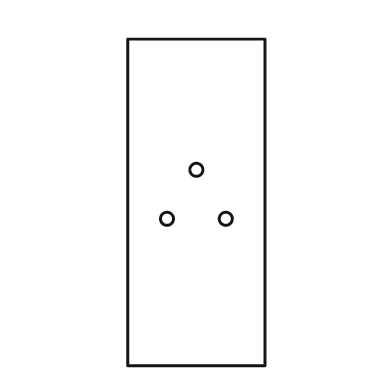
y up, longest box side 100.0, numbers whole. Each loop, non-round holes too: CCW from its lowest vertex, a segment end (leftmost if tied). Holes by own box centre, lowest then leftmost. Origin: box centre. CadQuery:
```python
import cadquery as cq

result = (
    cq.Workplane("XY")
    .moveTo(-21.0, -50.0)
    .lineTo(21.0, -50.0)
    .lineTo(21.0, 50.0)
    .lineTo(-21.0, 50.0)
    .close()
    .moveTo(-9.0, -5.0)
    .circle(2.0)
    .moveTo(9.0, -5.0)
    .circle(2.0)
    .moveTo(0.0, 10.0)
    .circle(2.0)
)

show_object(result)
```